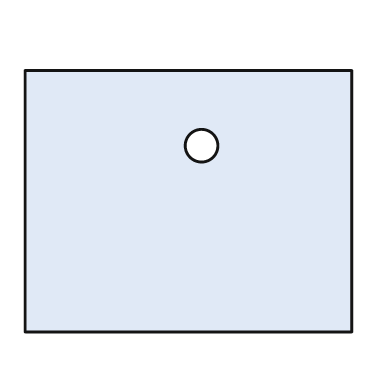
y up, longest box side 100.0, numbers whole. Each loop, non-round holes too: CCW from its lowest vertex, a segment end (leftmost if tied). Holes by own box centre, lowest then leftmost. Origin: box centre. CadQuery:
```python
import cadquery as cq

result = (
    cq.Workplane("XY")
    .moveTo(-50.0, -40.0)
    .lineTo(50.0, -40.0)
    .lineTo(50.0, 40.0)
    .lineTo(-50.0, 40.0)
    .close()
    .moveTo(4.0, 17.0)
    .circle(5.0)
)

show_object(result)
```